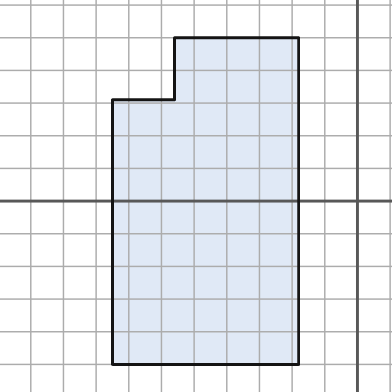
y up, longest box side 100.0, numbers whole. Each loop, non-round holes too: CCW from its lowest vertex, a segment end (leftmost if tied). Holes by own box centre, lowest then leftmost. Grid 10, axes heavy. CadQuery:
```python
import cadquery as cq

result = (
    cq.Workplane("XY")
    .moveTo(-75.0, -50.0)
    .lineTo(-18.0, -50.0)
    .lineTo(-18.0, 50.0)
    .lineTo(-56.0, 50.0)
    .lineTo(-56.0, 31.0)
    .lineTo(-75.0, 31.0)
    .close()
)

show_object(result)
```